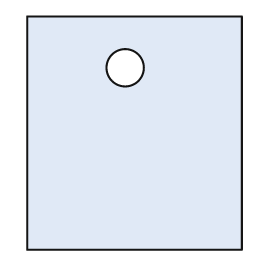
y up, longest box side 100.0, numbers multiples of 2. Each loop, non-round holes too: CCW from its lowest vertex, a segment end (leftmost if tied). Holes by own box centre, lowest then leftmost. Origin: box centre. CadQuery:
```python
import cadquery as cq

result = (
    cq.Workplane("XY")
    .moveTo(-46.0, -50.0)
    .lineTo(46.0, -50.0)
    .lineTo(46.0, 50.0)
    .lineTo(-46.0, 50.0)
    .close()
    .moveTo(-4.0, 28.0)
    .circle(8.0)
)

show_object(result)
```